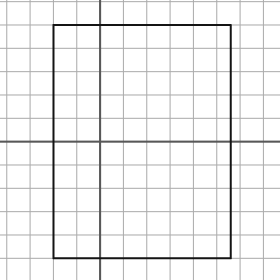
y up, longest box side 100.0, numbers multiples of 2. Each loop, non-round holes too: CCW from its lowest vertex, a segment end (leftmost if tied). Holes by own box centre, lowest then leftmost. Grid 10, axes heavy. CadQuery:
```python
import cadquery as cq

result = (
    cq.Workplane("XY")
    .moveTo(-20.0, -50.0)
    .lineTo(56.0, -50.0)
    .lineTo(56.0, 50.0)
    .lineTo(-20.0, 50.0)
    .close()
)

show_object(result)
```